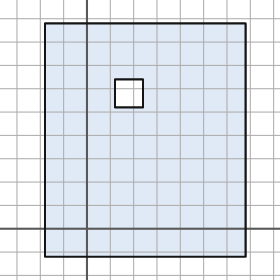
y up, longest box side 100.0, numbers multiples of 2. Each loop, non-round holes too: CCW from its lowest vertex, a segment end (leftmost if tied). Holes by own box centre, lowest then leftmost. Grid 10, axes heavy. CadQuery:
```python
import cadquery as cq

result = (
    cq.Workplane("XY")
    .moveTo(-18.0, -12.0)
    .lineTo(68.0, -12.0)
    .lineTo(68.0, 88.0)
    .lineTo(-18.0, 88.0)
    .close()
    .moveTo(12.0, 52.0)
    .lineTo(24.0, 52.0)
    .lineTo(24.0, 64.0)
    .lineTo(12.0, 64.0)
    .close()
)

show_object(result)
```